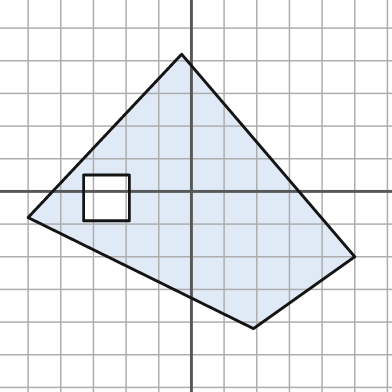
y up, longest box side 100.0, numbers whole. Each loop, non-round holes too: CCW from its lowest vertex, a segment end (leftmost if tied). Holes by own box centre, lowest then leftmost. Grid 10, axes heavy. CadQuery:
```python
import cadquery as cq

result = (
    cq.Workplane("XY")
    .moveTo(19.0, -42.0)
    .lineTo(50.0, -20.0)
    .lineTo(-3.0, 42.0)
    .lineTo(-50.0, -8.0)
    .close()
    .moveTo(-33.0, -9.0)
    .lineTo(-19.0, -9.0)
    .lineTo(-19.0, 5.0)
    .lineTo(-33.0, 5.0)
    .close()
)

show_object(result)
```